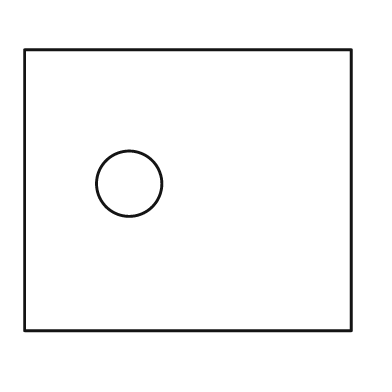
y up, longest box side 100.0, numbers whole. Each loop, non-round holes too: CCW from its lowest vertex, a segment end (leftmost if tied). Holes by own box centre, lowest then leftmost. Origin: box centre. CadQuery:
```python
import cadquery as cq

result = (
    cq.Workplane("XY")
    .moveTo(-50.0, -43.0)
    .lineTo(50.0, -43.0)
    .lineTo(50.0, 43.0)
    .lineTo(-50.0, 43.0)
    .close()
    .moveTo(-18.0, 2.0)
    .circle(10.0)
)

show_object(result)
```